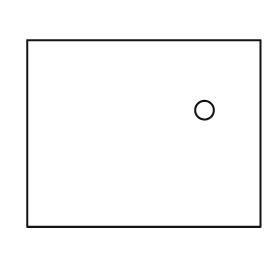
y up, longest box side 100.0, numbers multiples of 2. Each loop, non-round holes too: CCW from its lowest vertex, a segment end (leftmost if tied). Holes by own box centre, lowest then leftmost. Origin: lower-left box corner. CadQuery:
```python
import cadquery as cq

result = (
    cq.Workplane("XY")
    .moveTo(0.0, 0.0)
    .lineTo(100.0, 0.0)
    .lineTo(100.0, 80.0)
    .lineTo(0.0, 80.0)
    .close()
    .moveTo(76.0, 50.0)
    .circle(4.0)
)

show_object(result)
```